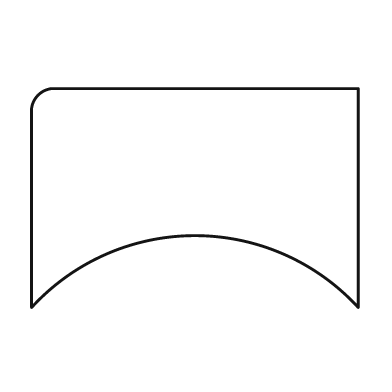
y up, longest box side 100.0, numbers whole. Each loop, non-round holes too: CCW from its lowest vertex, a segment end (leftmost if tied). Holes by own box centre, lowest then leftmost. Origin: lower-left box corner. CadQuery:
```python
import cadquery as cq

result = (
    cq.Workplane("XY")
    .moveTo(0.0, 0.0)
    .threePointArc((50.0, 22.0), (100.0, 0.0))
    .lineTo(100.0, 67.0)
    .lineTo(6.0, 67.0)
    .threePointArc((2.0, 65.0), (0.0, 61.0))
    .close()
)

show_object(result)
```